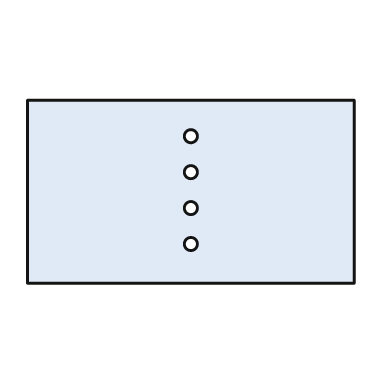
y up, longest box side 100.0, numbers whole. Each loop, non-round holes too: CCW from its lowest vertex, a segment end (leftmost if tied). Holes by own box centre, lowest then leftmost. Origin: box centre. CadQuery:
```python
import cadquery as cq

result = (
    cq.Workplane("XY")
    .moveTo(-50.0, -28.0)
    .lineTo(50.0, -28.0)
    .lineTo(50.0, 28.0)
    .lineTo(-50.0, 28.0)
    .close()
    .moveTo(0.0, -16.0)
    .circle(2.0)
    .moveTo(0.0, -5.0)
    .circle(2.0)
    .moveTo(0.0, 6.0)
    .circle(2.0)
    .moveTo(0.0, 17.0)
    .circle(2.0)
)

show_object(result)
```